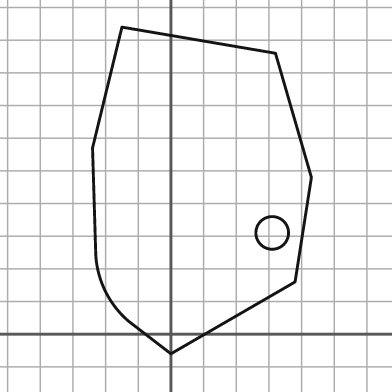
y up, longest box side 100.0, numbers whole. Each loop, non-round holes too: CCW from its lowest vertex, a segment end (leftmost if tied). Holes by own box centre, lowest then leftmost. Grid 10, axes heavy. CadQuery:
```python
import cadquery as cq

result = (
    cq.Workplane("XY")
    .moveTo(0.0, -6.0)
    .lineTo(38.0, 16.0)
    .lineTo(43.0, 48.0)
    .lineTo(32.0, 86.0)
    .lineTo(-15.0, 94.0)
    .lineTo(-24.0, 57.0)
    .lineTo(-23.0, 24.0)
    .threePointArc((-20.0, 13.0), (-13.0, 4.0))
    .close()
    .moveTo(31.0, 31.0)
    .circle(5.0)
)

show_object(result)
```